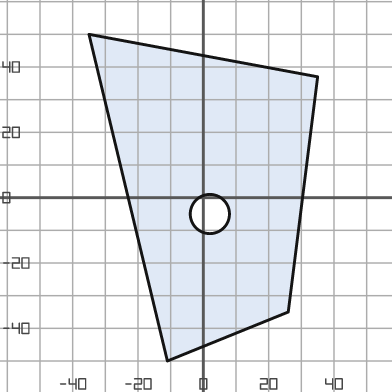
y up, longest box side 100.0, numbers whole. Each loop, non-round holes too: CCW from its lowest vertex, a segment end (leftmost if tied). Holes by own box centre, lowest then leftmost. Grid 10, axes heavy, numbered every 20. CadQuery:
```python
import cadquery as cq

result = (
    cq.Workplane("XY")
    .moveTo(-11.0, -50.0)
    .lineTo(26.0, -35.0)
    .lineTo(35.0, 37.0)
    .lineTo(-35.0, 50.0)
    .close()
    .moveTo(2.0, -5.0)
    .circle(6.0)
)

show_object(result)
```